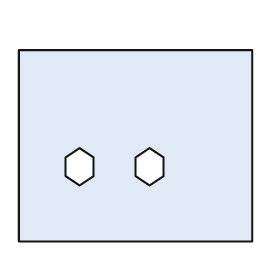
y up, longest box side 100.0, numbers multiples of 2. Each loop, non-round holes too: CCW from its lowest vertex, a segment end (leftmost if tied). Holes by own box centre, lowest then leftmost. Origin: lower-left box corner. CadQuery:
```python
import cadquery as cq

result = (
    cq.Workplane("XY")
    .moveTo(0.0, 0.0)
    .lineTo(100.0, 0.0)
    .lineTo(100.0, 82.0)
    .lineTo(0.0, 82.0)
    .close()
    .moveTo(26.0, 24.0)
    .lineTo(32.0, 28.0)
    .lineTo(32.0, 36.0)
    .lineTo(26.0, 40.0)
    .lineTo(20.0, 36.0)
    .lineTo(20.0, 28.0)
    .close()
    .moveTo(56.0, 24.0)
    .lineTo(62.0, 28.0)
    .lineTo(62.0, 36.0)
    .lineTo(56.0, 40.0)
    .lineTo(50.0, 36.0)
    .lineTo(50.0, 28.0)
    .close()
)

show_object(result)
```